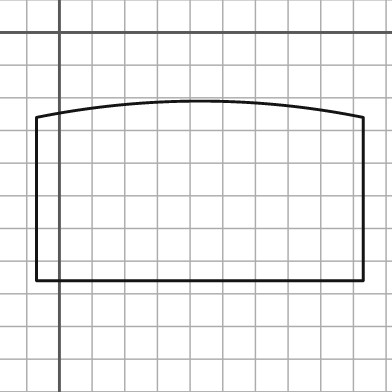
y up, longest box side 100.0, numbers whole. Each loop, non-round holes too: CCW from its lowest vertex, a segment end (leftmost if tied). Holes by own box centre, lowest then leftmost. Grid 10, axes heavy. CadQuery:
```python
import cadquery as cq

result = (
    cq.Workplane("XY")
    .moveTo(-7.0, -76.0)
    .lineTo(93.0, -76.0)
    .lineTo(93.0, -26.0)
    .threePointArc((43.0, -21.0), (-7.0, -26.0))
    .close()
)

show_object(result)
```